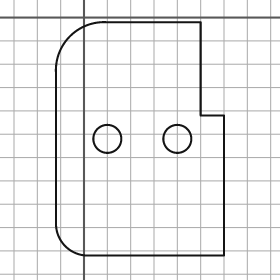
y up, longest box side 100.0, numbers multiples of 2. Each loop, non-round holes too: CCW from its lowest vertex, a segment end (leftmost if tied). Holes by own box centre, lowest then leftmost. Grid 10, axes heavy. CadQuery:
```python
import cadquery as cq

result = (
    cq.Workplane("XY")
    .moveTo(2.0, -102.0)
    .lineTo(60.0, -102.0)
    .lineTo(60.0, -42.0)
    .lineTo(50.0, -42.0)
    .lineTo(50.0, -2.0)
    .lineTo(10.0, -2.0)
    .threePointArc((-6.0, -8.0), (-12.0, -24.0))
    .lineTo(-12.0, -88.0)
    .threePointArc((-8.0, -98.0), (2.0, -102.0))
    .close()
    .moveTo(10.0, -52.0)
    .circle(6.0)
    .moveTo(40.0, -52.0)
    .circle(6.0)
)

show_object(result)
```